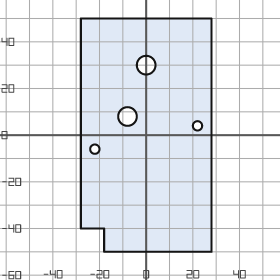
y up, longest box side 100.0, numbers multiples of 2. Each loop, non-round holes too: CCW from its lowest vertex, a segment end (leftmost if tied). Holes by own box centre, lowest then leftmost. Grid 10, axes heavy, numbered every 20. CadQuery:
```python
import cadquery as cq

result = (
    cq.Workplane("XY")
    .moveTo(-18.0, -50.0)
    .lineTo(28.0, -50.0)
    .lineTo(28.0, 50.0)
    .lineTo(-28.0, 50.0)
    .lineTo(-28.0, -40.0)
    .lineTo(-18.0, -40.0)
    .close()
    .moveTo(-22.0, -6.0)
    .circle(2.0)
    .moveTo(22.0, 4.0)
    .circle(2.0)
    .moveTo(-8.0, 8.0)
    .circle(4.0)
    .moveTo(0.0, 30.0)
    .circle(4.0)
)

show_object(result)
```